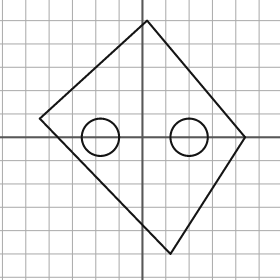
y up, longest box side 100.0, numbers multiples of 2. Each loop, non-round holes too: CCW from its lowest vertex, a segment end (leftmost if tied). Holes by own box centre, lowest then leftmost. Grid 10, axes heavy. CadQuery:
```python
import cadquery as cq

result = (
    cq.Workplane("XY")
    .moveTo(12.0, -50.0)
    .lineTo(44.0, 0.0)
    .lineTo(2.0, 50.0)
    .lineTo(-44.0, 8.0)
    .close()
    .moveTo(-18.0, 0.0)
    .circle(8.0)
    .moveTo(20.0, 0.0)
    .circle(8.0)
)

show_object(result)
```